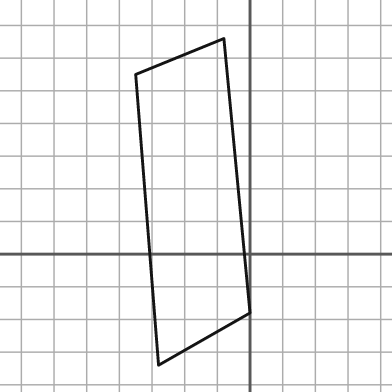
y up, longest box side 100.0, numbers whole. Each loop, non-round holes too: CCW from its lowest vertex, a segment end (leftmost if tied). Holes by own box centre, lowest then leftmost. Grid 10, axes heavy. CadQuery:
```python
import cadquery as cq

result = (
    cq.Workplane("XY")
    .moveTo(-28.0, -34.0)
    .lineTo(0.0, -18.0)
    .lineTo(-8.0, 66.0)
    .lineTo(-35.0, 55.0)
    .close()
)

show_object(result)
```